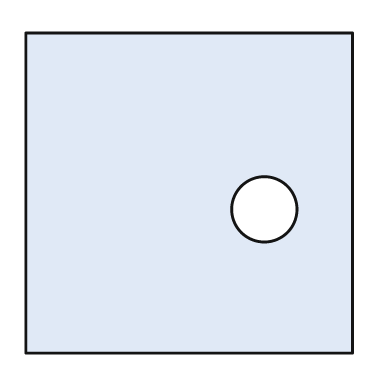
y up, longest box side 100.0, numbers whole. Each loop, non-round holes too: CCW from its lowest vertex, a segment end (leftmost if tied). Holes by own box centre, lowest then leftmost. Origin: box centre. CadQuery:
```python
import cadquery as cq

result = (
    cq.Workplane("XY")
    .moveTo(-50.0, -49.0)
    .lineTo(50.0, -49.0)
    .lineTo(50.0, 49.0)
    .lineTo(-50.0, 49.0)
    .close()
    .moveTo(23.0, -5.0)
    .circle(10.0)
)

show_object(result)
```